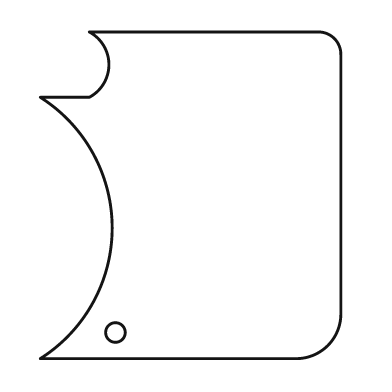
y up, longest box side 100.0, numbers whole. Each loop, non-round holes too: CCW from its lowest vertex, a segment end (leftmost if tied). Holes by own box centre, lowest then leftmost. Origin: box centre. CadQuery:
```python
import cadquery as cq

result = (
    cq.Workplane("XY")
    .moveTo(-46.0, -50.0)
    .lineTo(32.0, -50.0)
    .threePointArc((42.0, -46.0), (46.0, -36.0))
    .lineTo(46.0, 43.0)
    .threePointArc((44.0, 48.0), (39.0, 50.0))
    .lineTo(-31.0, 50.0)
    .threePointArc((-25.0, 40.0), (-31.0, 30.0))
    .lineTo(-46.0, 30.0)
    .threePointArc((-24.0, -10.0), (-46.0, -50.0))
    .close()
    .moveTo(-23.0, -42.0)
    .circle(3.0)
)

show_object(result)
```